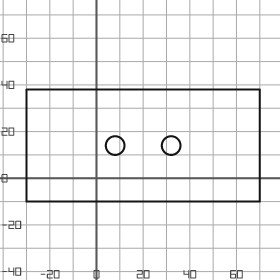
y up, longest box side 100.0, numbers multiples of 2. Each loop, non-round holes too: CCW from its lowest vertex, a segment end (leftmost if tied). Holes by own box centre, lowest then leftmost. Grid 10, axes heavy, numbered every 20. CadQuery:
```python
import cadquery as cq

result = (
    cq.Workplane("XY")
    .moveTo(-30.0, -10.0)
    .lineTo(70.0, -10.0)
    .lineTo(70.0, 38.0)
    .lineTo(-30.0, 38.0)
    .close()
    .moveTo(8.0, 14.0)
    .circle(4.0)
    .moveTo(32.0, 14.0)
    .circle(4.0)
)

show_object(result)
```